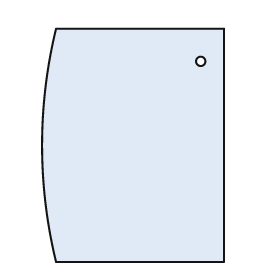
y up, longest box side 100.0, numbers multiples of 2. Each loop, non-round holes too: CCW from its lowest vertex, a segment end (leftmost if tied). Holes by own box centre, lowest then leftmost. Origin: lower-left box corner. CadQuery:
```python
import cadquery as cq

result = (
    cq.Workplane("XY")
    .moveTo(6.0, 0.0)
    .lineTo(78.0, 0.0)
    .lineTo(78.0, 100.0)
    .lineTo(6.0, 100.0)
    .threePointArc((0.0, 50.0), (6.0, 0.0))
    .close()
    .moveTo(68.0, 86.0)
    .circle(2.0)
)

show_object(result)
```